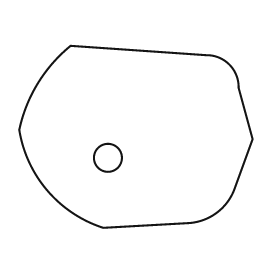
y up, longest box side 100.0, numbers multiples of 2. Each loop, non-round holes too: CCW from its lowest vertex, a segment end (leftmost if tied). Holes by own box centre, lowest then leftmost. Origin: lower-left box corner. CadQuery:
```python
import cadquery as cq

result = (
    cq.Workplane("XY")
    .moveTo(36.0, 0.0)
    .lineTo(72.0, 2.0)
    .threePointArc((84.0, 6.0), (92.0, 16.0))
    .lineTo(100.0, 38.0)
    .lineTo(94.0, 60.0)
    .threePointArc((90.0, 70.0), (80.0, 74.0))
    .lineTo(22.0, 78.0)
    .threePointArc((8.0, 62.0), (0.0, 42.0))
    .threePointArc((12.0, 16.0), (36.0, 0.0))
    .close()
    .moveTo(38.0, 30.0)
    .circle(6.0)
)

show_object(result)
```